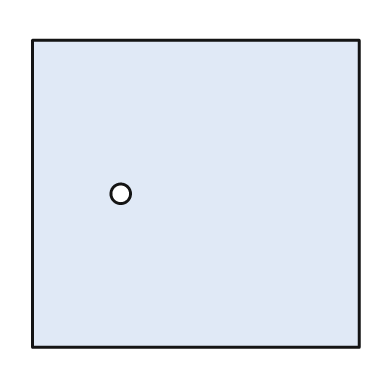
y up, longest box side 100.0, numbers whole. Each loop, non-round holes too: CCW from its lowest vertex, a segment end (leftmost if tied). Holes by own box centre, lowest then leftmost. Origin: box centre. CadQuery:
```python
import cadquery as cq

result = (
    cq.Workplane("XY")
    .moveTo(-50.0, -47.0)
    .lineTo(50.0, -47.0)
    .lineTo(50.0, 47.0)
    .lineTo(-50.0, 47.0)
    .close()
    .moveTo(-23.0, 0.0)
    .circle(3.0)
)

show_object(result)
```